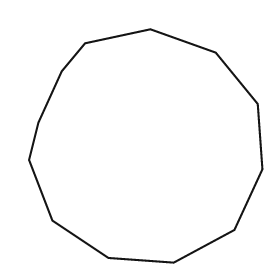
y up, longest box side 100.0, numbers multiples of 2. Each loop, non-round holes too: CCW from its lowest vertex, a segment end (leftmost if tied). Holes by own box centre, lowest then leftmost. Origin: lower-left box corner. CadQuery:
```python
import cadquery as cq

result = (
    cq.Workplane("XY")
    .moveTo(62.0, 0.0)
    .lineTo(88.0, 14.0)
    .lineTo(100.0, 40.0)
    .lineTo(98.0, 68.0)
    .lineTo(80.0, 90.0)
    .lineTo(52.0, 100.0)
    .lineTo(24.0, 94.0)
    .lineTo(14.0, 82.0)
    .lineTo(4.0, 60.0)
    .lineTo(0.0, 44.0)
    .lineTo(10.0, 18.0)
    .lineTo(34.0, 2.0)
    .close()
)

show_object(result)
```